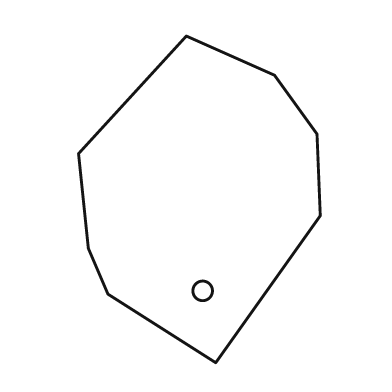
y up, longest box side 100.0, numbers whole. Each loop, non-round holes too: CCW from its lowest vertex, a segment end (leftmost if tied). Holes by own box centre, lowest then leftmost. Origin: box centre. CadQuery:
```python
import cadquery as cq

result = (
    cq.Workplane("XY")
    .moveTo(5.0, -50.0)
    .lineTo(37.0, -5.0)
    .lineTo(36.0, 20.0)
    .lineTo(23.0, 38.0)
    .lineTo(-4.0, 50.0)
    .lineTo(-37.0, 14.0)
    .lineTo(-34.0, -15.0)
    .lineTo(-28.0, -29.0)
    .close()
    .moveTo(1.0, -28.0)
    .circle(3.0)
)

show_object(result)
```